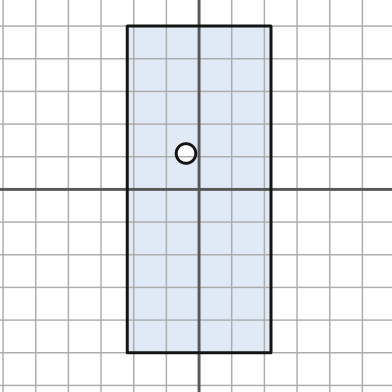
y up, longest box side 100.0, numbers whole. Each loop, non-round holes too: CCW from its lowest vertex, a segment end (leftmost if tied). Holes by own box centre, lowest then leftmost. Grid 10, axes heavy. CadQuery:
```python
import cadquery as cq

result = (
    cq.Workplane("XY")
    .moveTo(-22.0, -50.0)
    .lineTo(22.0, -50.0)
    .lineTo(22.0, 50.0)
    .lineTo(-22.0, 50.0)
    .close()
    .moveTo(-4.0, 11.0)
    .circle(3.0)
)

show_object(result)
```